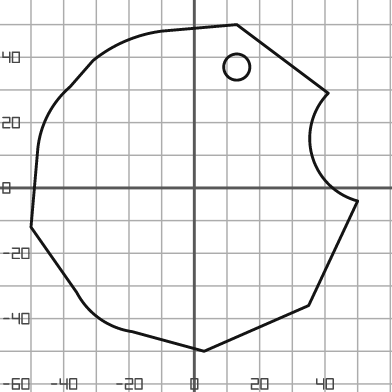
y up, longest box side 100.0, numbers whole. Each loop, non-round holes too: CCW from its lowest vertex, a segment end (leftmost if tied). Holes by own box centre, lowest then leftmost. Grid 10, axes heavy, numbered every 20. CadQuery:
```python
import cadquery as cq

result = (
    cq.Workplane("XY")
    .moveTo(3.0, -50.0)
    .lineTo(35.0, -36.0)
    .lineTo(50.0, -4.0)
    .threePointArc((36.0, 10.0), (41.0, 29.0))
    .lineTo(13.0, 50.0)
    .lineTo(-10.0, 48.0)
    .threePointArc((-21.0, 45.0), (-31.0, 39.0))
    .lineTo(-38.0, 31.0)
    .threePointArc((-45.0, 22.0), (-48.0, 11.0))
    .lineTo(-50.0, -12.0)
    .lineTo(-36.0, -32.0)
    .threePointArc((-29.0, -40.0), (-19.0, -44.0))
    .close()
    .moveTo(13.0, 37.0)
    .circle(4.0)
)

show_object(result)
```